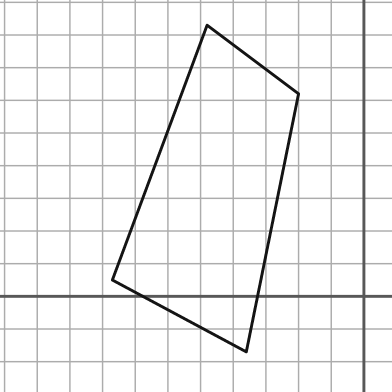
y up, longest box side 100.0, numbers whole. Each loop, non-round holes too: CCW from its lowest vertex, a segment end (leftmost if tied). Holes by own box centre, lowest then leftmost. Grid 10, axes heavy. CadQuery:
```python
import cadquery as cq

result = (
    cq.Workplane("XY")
    .moveTo(-36.0, -17.0)
    .lineTo(-20.0, 62.0)
    .lineTo(-48.0, 83.0)
    .lineTo(-77.0, 5.0)
    .close()
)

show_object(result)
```